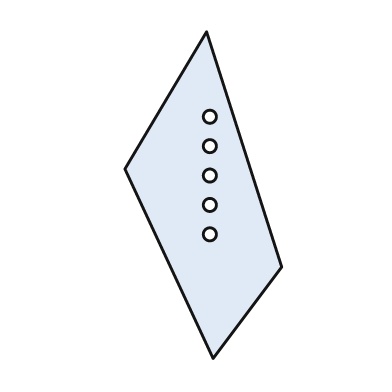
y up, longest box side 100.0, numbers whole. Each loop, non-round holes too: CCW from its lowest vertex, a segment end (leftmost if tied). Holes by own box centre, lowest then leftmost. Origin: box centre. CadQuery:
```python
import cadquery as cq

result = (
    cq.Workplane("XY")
    .moveTo(3.0, -50.0)
    .lineTo(24.0, -22.0)
    .lineTo(1.0, 50.0)
    .lineTo(-24.0, 8.0)
    .close()
    .moveTo(2.0, -12.0)
    .circle(2.0)
    .moveTo(2.0, -3.0)
    .circle(2.0)
    .moveTo(2.0, 6.0)
    .circle(2.0)
    .moveTo(2.0, 15.0)
    .circle(2.0)
    .moveTo(2.0, 24.0)
    .circle(2.0)
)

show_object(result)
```